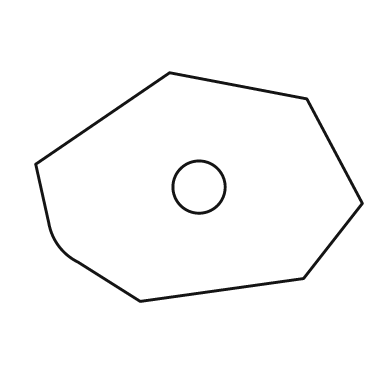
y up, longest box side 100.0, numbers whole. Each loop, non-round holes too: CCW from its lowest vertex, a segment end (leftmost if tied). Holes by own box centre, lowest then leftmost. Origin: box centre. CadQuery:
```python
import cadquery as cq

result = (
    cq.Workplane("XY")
    .moveTo(-18.0, -35.0)
    .lineTo(32.0, -28.0)
    .lineTo(50.0, -5.0)
    .lineTo(33.0, 27.0)
    .lineTo(-9.0, 35.0)
    .lineTo(-50.0, 7.0)
    .lineTo(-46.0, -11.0)
    .threePointArc((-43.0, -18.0), (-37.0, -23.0))
    .close()
    .moveTo(0.0, 0.0)
    .circle(8.0)
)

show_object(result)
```